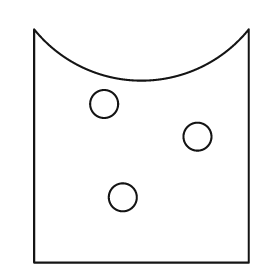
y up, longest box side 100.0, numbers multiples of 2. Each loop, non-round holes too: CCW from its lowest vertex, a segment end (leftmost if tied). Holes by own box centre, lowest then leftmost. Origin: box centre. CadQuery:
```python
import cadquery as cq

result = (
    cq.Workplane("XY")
    .moveTo(-46.0, -50.0)
    .lineTo(46.0, -50.0)
    .lineTo(46.0, 50.0)
    .threePointArc((0.0, 28.0), (-46.0, 50.0))
    .close()
    .moveTo(-8.0, -22.0)
    .circle(6.0)
    .moveTo(24.0, 4.0)
    .circle(6.0)
    .moveTo(-16.0, 18.0)
    .circle(6.0)
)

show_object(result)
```